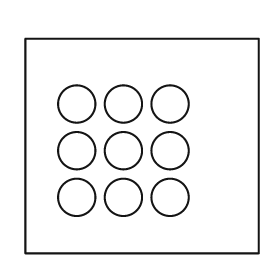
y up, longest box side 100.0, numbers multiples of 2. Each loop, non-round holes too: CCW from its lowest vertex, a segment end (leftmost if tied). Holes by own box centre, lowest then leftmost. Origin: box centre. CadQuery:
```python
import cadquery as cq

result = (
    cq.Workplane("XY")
    .moveTo(-50.0, -46.0)
    .lineTo(50.0, -46.0)
    .lineTo(50.0, 46.0)
    .lineTo(-50.0, 46.0)
    .close()
    .moveTo(-28.0, -22.0)
    .circle(8.0)
    .moveTo(-8.0, -22.0)
    .circle(8.0)
    .moveTo(12.0, -22.0)
    .circle(8.0)
    .moveTo(-28.0, -2.0)
    .circle(8.0)
    .moveTo(-8.0, -2.0)
    .circle(8.0)
    .moveTo(12.0, -2.0)
    .circle(8.0)
    .moveTo(-28.0, 18.0)
    .circle(8.0)
    .moveTo(-8.0, 18.0)
    .circle(8.0)
    .moveTo(12.0, 18.0)
    .circle(8.0)
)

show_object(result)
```